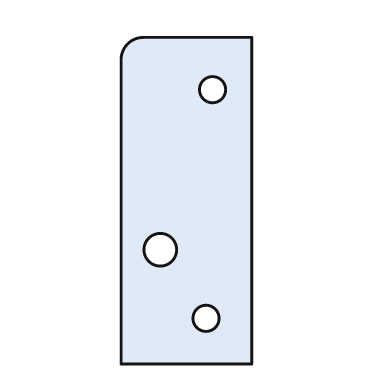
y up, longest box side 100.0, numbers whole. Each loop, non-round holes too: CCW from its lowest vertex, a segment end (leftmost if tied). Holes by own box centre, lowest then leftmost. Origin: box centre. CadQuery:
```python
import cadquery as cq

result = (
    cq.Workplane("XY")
    .moveTo(-20.0, -50.0)
    .lineTo(20.0, -50.0)
    .lineTo(20.0, 50.0)
    .lineTo(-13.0, 50.0)
    .threePointArc((-18.0, 48.0), (-20.0, 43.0))
    .close()
    .moveTo(6.0, -36.0)
    .circle(4.0)
    .moveTo(-8.0, -15.0)
    .circle(5.0)
    .moveTo(8.0, 34.0)
    .circle(4.0)
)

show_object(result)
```